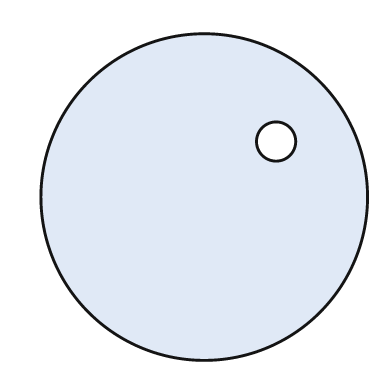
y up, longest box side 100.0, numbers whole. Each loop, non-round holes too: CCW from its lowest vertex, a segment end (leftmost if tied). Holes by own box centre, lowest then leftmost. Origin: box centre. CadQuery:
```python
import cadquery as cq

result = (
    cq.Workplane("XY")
    .moveTo(0.0, 0.0)
    .circle(50.0)
    .moveTo(22.0, 17.0)
    .circle(6.0)
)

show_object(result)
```